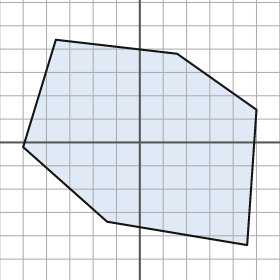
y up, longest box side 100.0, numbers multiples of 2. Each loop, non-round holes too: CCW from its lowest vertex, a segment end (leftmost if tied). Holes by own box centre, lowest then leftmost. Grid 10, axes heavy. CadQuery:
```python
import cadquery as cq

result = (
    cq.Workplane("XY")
    .moveTo(46.0, -44.0)
    .lineTo(50.0, 14.0)
    .lineTo(16.0, 38.0)
    .lineTo(-36.0, 44.0)
    .lineTo(-50.0, -2.0)
    .lineTo(-14.0, -34.0)
    .close()
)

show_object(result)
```